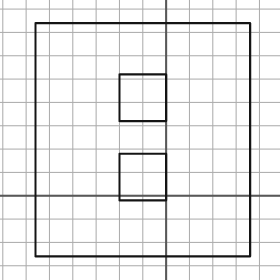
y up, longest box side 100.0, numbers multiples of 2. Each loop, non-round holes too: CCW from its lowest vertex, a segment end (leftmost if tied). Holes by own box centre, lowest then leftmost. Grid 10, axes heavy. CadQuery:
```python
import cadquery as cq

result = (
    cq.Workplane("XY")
    .moveTo(-56.0, -26.0)
    .lineTo(36.0, -26.0)
    .lineTo(36.0, 74.0)
    .lineTo(-56.0, 74.0)
    .close()
    .moveTo(-20.0, -2.0)
    .lineTo(0.0, -2.0)
    .lineTo(0.0, 18.0)
    .lineTo(-20.0, 18.0)
    .close()
    .moveTo(-20.0, 32.0)
    .lineTo(0.0, 32.0)
    .lineTo(0.0, 52.0)
    .lineTo(-20.0, 52.0)
    .close()
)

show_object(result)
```